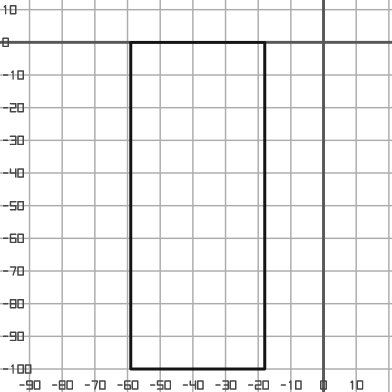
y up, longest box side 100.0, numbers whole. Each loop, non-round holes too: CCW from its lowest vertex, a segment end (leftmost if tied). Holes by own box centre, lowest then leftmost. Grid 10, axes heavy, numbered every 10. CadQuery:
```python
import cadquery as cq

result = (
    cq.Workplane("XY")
    .moveTo(-59.0, -100.0)
    .lineTo(-18.0, -100.0)
    .lineTo(-18.0, 0.0)
    .lineTo(-59.0, 0.0)
    .close()
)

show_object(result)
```